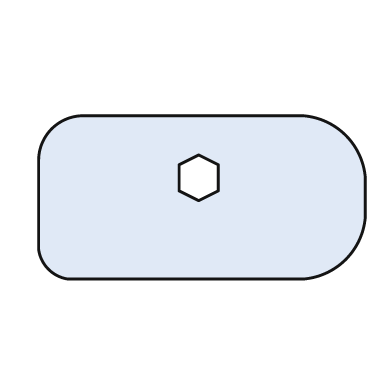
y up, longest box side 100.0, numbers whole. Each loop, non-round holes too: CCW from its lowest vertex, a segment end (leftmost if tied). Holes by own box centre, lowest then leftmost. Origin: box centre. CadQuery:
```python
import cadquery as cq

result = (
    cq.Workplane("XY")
    .moveTo(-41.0, -25.0)
    .lineTo(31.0, -25.0)
    .threePointArc((44.0, -19.0), (50.0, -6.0))
    .lineTo(50.0, 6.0)
    .threePointArc((44.0, 19.0), (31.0, 25.0))
    .lineTo(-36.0, 25.0)
    .threePointArc((-46.0, 21.0), (-50.0, 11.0))
    .lineTo(-50.0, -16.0)
    .threePointArc((-47.0, -22.0), (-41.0, -25.0))
    .close()
    .moveTo(-1.0, -1.0)
    .lineTo(5.0, 2.0)
    .lineTo(5.0, 10.0)
    .lineTo(-1.0, 13.0)
    .lineTo(-7.0, 10.0)
    .lineTo(-7.0, 2.0)
    .close()
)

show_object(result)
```